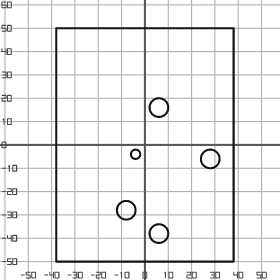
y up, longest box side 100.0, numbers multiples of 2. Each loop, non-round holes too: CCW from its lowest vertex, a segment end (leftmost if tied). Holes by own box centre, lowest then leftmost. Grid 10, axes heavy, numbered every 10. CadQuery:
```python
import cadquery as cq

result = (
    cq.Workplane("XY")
    .moveTo(-38.0, -50.0)
    .lineTo(38.0, -50.0)
    .lineTo(38.0, 50.0)
    .lineTo(-38.0, 50.0)
    .close()
    .moveTo(6.0, -38.0)
    .circle(4.0)
    .moveTo(-8.0, -28.0)
    .circle(4.0)
    .moveTo(28.0, -6.0)
    .circle(4.0)
    .moveTo(-4.0, -4.0)
    .circle(2.0)
    .moveTo(6.0, 16.0)
    .circle(4.0)
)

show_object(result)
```